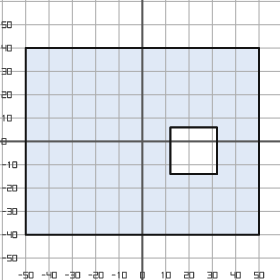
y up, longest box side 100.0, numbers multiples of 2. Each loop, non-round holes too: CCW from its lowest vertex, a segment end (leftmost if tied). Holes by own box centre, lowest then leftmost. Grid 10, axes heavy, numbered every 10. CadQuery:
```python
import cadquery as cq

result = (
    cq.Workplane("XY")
    .moveTo(-50.0, -40.0)
    .lineTo(50.0, -40.0)
    .lineTo(50.0, 40.0)
    .lineTo(-50.0, 40.0)
    .close()
    .moveTo(12.0, -14.0)
    .lineTo(32.0, -14.0)
    .lineTo(32.0, 6.0)
    .lineTo(12.0, 6.0)
    .close()
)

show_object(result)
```